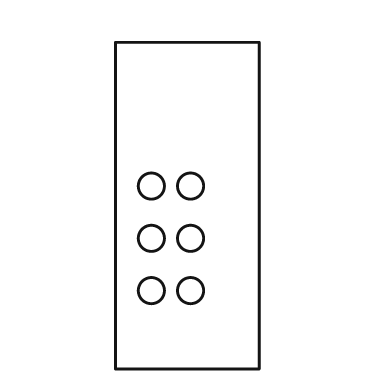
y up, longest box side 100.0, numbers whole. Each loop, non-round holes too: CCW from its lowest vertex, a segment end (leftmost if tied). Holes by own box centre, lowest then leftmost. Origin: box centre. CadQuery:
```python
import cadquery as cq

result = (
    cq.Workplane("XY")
    .moveTo(-22.0, -50.0)
    .lineTo(22.0, -50.0)
    .lineTo(22.0, 50.0)
    .lineTo(-22.0, 50.0)
    .close()
    .moveTo(-11.0, -26.0)
    .circle(4.0)
    .moveTo(1.0, -26.0)
    .circle(4.0)
    .moveTo(-11.0, -10.0)
    .circle(4.0)
    .moveTo(1.0, -10.0)
    .circle(4.0)
    .moveTo(-11.0, 6.0)
    .circle(4.0)
    .moveTo(1.0, 6.0)
    .circle(4.0)
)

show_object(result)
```